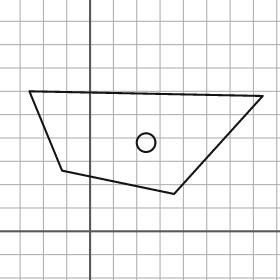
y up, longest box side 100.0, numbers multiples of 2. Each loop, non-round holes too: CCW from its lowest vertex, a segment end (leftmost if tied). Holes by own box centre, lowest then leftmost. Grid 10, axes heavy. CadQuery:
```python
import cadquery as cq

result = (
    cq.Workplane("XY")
    .moveTo(36.0, 16.0)
    .lineTo(74.0, 58.0)
    .lineTo(-26.0, 60.0)
    .lineTo(-12.0, 26.0)
    .close()
    .moveTo(24.0, 38.0)
    .circle(4.0)
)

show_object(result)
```